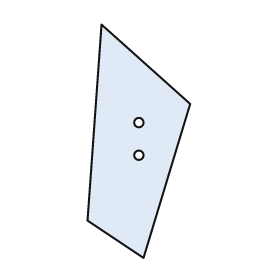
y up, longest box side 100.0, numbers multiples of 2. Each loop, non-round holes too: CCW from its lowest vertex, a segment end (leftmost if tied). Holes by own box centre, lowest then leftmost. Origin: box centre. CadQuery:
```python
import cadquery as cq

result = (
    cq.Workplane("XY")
    .moveTo(2.0, -50.0)
    .lineTo(22.0, 16.0)
    .lineTo(-16.0, 50.0)
    .lineTo(-22.0, -34.0)
    .close()
    .moveTo(0.0, -6.0)
    .circle(2.0)
    .moveTo(0.0, 8.0)
    .circle(2.0)
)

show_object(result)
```